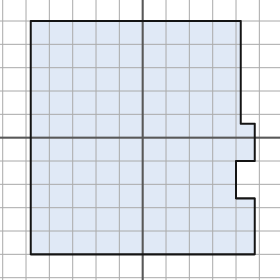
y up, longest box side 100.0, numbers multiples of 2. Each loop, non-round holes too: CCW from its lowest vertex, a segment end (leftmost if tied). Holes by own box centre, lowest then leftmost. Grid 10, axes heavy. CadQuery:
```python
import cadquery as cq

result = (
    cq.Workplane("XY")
    .moveTo(-48.0, -50.0)
    .lineTo(48.0, -50.0)
    .lineTo(48.0, -26.0)
    .lineTo(40.0, -26.0)
    .lineTo(40.0, -10.0)
    .lineTo(48.0, -10.0)
    .lineTo(48.0, 6.0)
    .lineTo(42.0, 6.0)
    .lineTo(42.0, 50.0)
    .lineTo(-48.0, 50.0)
    .close()
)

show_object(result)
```